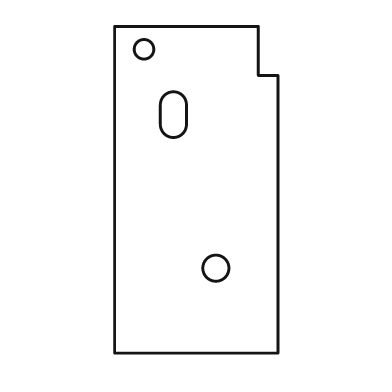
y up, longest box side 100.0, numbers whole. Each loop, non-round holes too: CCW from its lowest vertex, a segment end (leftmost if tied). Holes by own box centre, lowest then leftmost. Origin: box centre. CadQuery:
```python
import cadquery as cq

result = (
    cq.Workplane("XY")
    .moveTo(-25.0, -50.0)
    .lineTo(25.0, -50.0)
    .lineTo(25.0, 35.0)
    .lineTo(19.0, 35.0)
    .lineTo(19.0, 50.0)
    .lineTo(-25.0, 50.0)
    .close()
    .moveTo(6.0, -24.0)
    .circle(4.0)
    .moveTo(-11.0, 20.0)
    .threePointArc((-7.0, 16.0), (-3.0, 20.0))
    .lineTo(-3.0, 26.0)
    .threePointArc((-7.0, 30.0), (-11.0, 26.0))
    .close()
    .moveTo(-16.0, 43.0)
    .circle(3.0)
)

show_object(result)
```